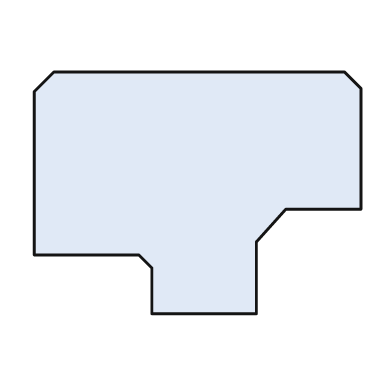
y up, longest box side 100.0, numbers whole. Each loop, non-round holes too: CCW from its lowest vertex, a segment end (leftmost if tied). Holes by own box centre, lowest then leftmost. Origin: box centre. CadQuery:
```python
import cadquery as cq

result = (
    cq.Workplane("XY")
    .moveTo(-14.0, -37.0)
    .lineTo(18.0, -37.0)
    .lineTo(18.0, -15.0)
    .lineTo(27.0, -5.0)
    .lineTo(50.0, -5.0)
    .lineTo(50.0, 32.0)
    .lineTo(45.0, 37.0)
    .lineTo(-44.0, 37.0)
    .lineTo(-50.0, 31.0)
    .lineTo(-50.0, -19.0)
    .lineTo(-18.0, -19.0)
    .lineTo(-14.0, -23.0)
    .close()
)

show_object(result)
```